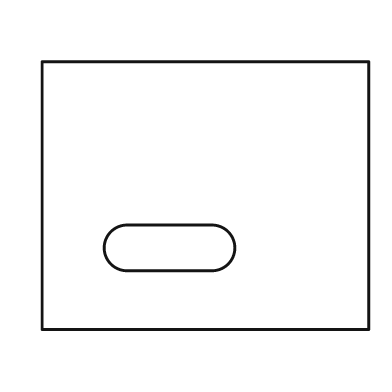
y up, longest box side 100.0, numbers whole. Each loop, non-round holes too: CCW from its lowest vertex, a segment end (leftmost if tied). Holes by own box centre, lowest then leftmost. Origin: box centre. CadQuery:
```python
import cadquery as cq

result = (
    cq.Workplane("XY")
    .moveTo(-50.0, -41.0)
    .lineTo(50.0, -41.0)
    .lineTo(50.0, 41.0)
    .lineTo(-50.0, 41.0)
    .close()
    .moveTo(-24.0, -23.0)
    .lineTo(2.0, -23.0)
    .threePointArc((9.0, -16.0), (2.0, -9.0))
    .lineTo(-24.0, -9.0)
    .threePointArc((-31.0, -16.0), (-24.0, -23.0))
    .close()
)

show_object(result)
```